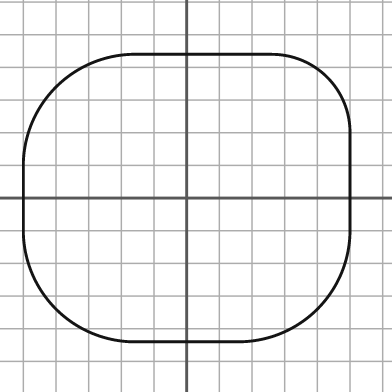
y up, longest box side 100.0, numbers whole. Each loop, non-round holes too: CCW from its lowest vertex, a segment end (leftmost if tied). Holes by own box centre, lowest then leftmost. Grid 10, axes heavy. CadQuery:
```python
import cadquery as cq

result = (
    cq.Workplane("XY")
    .moveTo(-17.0, -44.0)
    .lineTo(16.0, -44.0)
    .threePointArc((40.0, -34.0), (50.0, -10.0))
    .lineTo(50.0, 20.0)
    .threePointArc((43.0, 37.0), (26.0, 44.0))
    .lineTo(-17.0, 44.0)
    .threePointArc((-40.0, 34.0), (-50.0, 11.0))
    .lineTo(-50.0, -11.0)
    .threePointArc((-40.0, -34.0), (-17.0, -44.0))
    .close()
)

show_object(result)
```